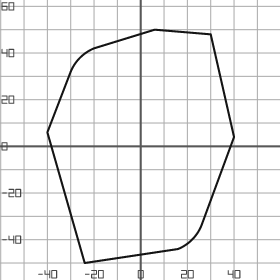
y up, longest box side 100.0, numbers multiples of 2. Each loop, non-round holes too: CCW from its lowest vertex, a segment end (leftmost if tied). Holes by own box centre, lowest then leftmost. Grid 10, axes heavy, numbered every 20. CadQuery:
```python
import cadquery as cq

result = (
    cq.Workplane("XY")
    .moveTo(-24.0, -50.0)
    .lineTo(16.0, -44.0)
    .threePointArc((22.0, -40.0), (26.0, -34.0))
    .lineTo(40.0, 4.0)
    .lineTo(30.0, 48.0)
    .lineTo(6.0, 50.0)
    .lineTo(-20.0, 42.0)
    .threePointArc((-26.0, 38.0), (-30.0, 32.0))
    .lineTo(-40.0, 6.0)
    .close()
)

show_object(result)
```